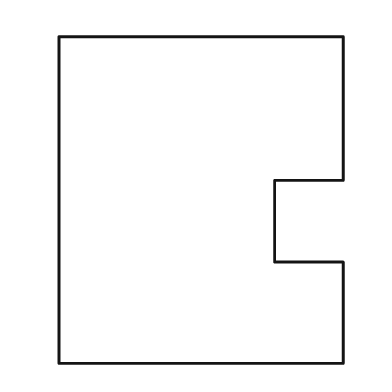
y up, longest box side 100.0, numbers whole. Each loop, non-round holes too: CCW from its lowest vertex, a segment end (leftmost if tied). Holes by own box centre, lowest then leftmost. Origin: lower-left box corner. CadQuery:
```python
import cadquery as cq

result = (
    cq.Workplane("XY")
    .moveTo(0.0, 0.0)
    .lineTo(87.0, 0.0)
    .lineTo(87.0, 31.0)
    .lineTo(66.0, 31.0)
    .lineTo(66.0, 56.0)
    .lineTo(87.0, 56.0)
    .lineTo(87.0, 100.0)
    .lineTo(0.0, 100.0)
    .close()
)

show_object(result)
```